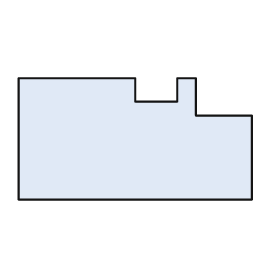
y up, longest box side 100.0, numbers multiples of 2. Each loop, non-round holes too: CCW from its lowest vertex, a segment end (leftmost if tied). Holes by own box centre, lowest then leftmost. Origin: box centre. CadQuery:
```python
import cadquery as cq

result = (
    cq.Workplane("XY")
    .moveTo(-50.0, -26.0)
    .lineTo(50.0, -26.0)
    .lineTo(50.0, 10.0)
    .lineTo(26.0, 10.0)
    .lineTo(26.0, 26.0)
    .lineTo(18.0, 26.0)
    .lineTo(18.0, 16.0)
    .lineTo(0.0, 16.0)
    .lineTo(0.0, 26.0)
    .lineTo(-50.0, 26.0)
    .close()
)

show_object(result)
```